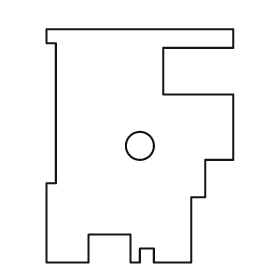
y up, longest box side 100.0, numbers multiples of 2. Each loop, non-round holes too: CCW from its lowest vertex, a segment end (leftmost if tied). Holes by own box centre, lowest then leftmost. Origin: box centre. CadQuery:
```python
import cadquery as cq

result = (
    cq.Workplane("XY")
    .moveTo(-40.0, -50.0)
    .lineTo(-22.0, -50.0)
    .lineTo(-22.0, -38.0)
    .lineTo(-4.0, -38.0)
    .lineTo(-4.0, -50.0)
    .lineTo(0.0, -50.0)
    .lineTo(0.0, -44.0)
    .lineTo(6.0, -44.0)
    .lineTo(6.0, -50.0)
    .lineTo(22.0, -50.0)
    .lineTo(22.0, -22.0)
    .lineTo(28.0, -22.0)
    .lineTo(28.0, -6.0)
    .lineTo(40.0, -6.0)
    .lineTo(40.0, 22.0)
    .lineTo(10.0, 22.0)
    .lineTo(10.0, 42.0)
    .lineTo(40.0, 42.0)
    .lineTo(40.0, 50.0)
    .lineTo(-40.0, 50.0)
    .lineTo(-40.0, 44.0)
    .lineTo(-36.0, 44.0)
    .lineTo(-36.0, -16.0)
    .lineTo(-40.0, -16.0)
    .close()
    .moveTo(0.0, 0.0)
    .circle(6.0)
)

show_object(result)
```